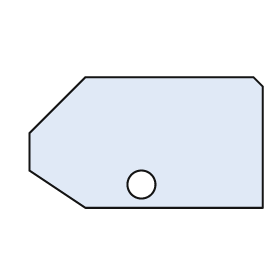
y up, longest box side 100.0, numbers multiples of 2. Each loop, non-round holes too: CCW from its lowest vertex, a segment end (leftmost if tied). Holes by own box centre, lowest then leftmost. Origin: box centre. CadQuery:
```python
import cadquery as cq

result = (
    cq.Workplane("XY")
    .moveTo(-26.0, -28.0)
    .lineTo(50.0, -28.0)
    .lineTo(50.0, 24.0)
    .lineTo(46.0, 28.0)
    .lineTo(-26.0, 28.0)
    .lineTo(-50.0, 4.0)
    .lineTo(-50.0, -12.0)
    .close()
    .moveTo(-2.0, -18.0)
    .circle(6.0)
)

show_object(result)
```